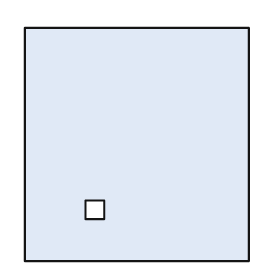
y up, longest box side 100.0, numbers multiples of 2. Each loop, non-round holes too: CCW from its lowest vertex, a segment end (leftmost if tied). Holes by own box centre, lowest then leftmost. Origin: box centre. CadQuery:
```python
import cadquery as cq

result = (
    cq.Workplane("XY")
    .moveTo(-48.0, -50.0)
    .lineTo(48.0, -50.0)
    .lineTo(48.0, 50.0)
    .lineTo(-48.0, 50.0)
    .close()
    .moveTo(-22.0, -32.0)
    .lineTo(-14.0, -32.0)
    .lineTo(-14.0, -24.0)
    .lineTo(-22.0, -24.0)
    .close()
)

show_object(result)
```